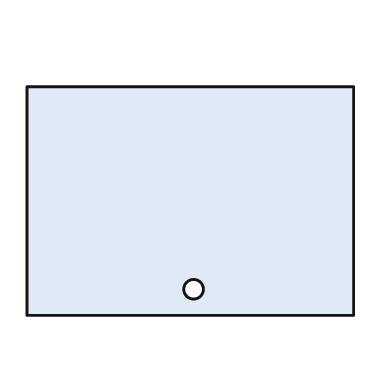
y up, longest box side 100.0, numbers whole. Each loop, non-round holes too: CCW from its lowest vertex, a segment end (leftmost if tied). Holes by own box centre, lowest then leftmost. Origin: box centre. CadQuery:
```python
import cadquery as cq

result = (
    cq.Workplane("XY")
    .moveTo(-50.0, -35.0)
    .lineTo(50.0, -35.0)
    .lineTo(50.0, 35.0)
    .lineTo(-50.0, 35.0)
    .close()
    .moveTo(1.0, -27.0)
    .circle(3.0)
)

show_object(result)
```